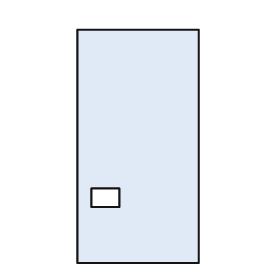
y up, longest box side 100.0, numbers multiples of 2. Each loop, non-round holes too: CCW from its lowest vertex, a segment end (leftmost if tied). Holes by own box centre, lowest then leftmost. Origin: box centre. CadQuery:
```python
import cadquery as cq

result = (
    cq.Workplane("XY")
    .moveTo(-26.0, -50.0)
    .lineTo(26.0, -50.0)
    .lineTo(26.0, 50.0)
    .lineTo(-26.0, 50.0)
    .close()
    .moveTo(-20.0, -26.0)
    .lineTo(-8.0, -26.0)
    .lineTo(-8.0, -18.0)
    .lineTo(-20.0, -18.0)
    .close()
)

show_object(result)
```